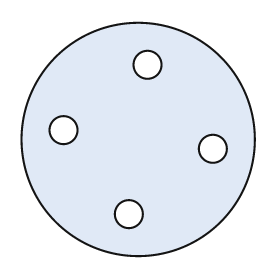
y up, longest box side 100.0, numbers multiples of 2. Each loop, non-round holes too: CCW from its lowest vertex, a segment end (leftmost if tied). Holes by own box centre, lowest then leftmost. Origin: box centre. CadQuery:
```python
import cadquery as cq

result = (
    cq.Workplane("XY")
    .moveTo(0.0, 0.0)
    .circle(50.0)
    .moveTo(-4.0, -32.0)
    .circle(6.0)
    .moveTo(32.0, -4.0)
    .circle(6.0)
    .moveTo(-32.0, 4.0)
    .circle(6.0)
    .moveTo(4.0, 32.0)
    .circle(6.0)
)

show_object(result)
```